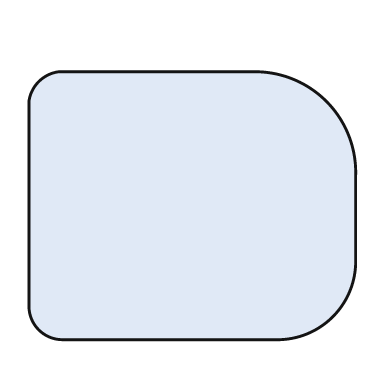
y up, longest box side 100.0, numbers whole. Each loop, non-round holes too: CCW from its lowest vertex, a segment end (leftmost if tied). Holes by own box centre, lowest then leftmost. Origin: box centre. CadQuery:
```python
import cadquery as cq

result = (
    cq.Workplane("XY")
    .moveTo(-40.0, -41.0)
    .lineTo(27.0, -41.0)
    .threePointArc((43.0, -34.0), (50.0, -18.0))
    .lineTo(50.0, 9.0)
    .threePointArc((41.0, 32.0), (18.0, 41.0))
    .lineTo(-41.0, 41.0)
    .threePointArc((-47.0, 38.0), (-50.0, 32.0))
    .lineTo(-50.0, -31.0)
    .threePointArc((-47.0, -38.0), (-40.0, -41.0))
    .close()
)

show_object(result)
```